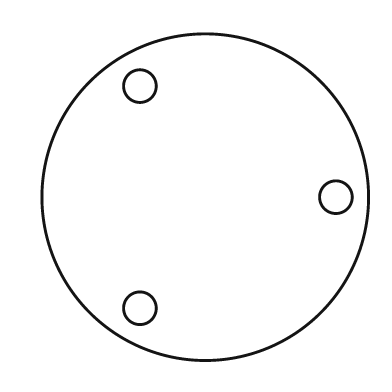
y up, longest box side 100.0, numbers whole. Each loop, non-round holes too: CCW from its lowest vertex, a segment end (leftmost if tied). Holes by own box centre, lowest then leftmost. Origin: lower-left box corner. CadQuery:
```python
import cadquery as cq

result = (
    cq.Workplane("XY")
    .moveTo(50.0, 50.0)
    .circle(50.0)
    .moveTo(30.0, 16.0)
    .circle(5.0)
    .moveTo(90.0, 50.0)
    .circle(5.0)
    .moveTo(30.0, 84.0)
    .circle(5.0)
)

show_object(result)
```